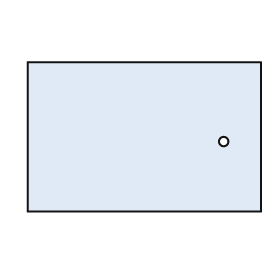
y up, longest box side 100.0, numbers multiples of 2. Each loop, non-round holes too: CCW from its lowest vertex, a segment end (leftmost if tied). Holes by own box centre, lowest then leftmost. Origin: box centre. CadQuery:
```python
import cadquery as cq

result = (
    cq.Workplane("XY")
    .moveTo(-50.0, -32.0)
    .lineTo(50.0, -32.0)
    .lineTo(50.0, 32.0)
    .lineTo(-50.0, 32.0)
    .close()
    .moveTo(34.0, -2.0)
    .circle(2.0)
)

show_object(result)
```